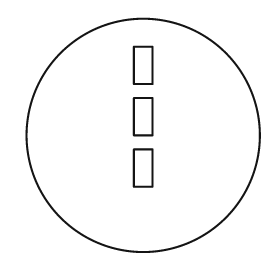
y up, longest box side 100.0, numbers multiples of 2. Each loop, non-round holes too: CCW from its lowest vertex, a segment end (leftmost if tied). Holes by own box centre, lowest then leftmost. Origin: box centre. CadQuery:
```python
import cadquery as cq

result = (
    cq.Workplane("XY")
    .moveTo(0.0, 0.0)
    .circle(50.0)
    .moveTo(-4.0, -22.0)
    .lineTo(4.0, -22.0)
    .lineTo(4.0, -6.0)
    .lineTo(-4.0, -6.0)
    .close()
    .moveTo(-4.0, 0.0)
    .lineTo(4.0, 0.0)
    .lineTo(4.0, 16.0)
    .lineTo(-4.0, 16.0)
    .close()
    .moveTo(-4.0, 22.0)
    .lineTo(4.0, 22.0)
    .lineTo(4.0, 38.0)
    .lineTo(-4.0, 38.0)
    .close()
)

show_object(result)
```